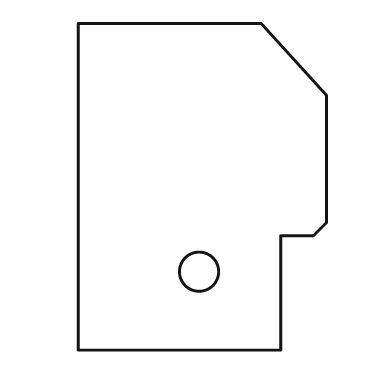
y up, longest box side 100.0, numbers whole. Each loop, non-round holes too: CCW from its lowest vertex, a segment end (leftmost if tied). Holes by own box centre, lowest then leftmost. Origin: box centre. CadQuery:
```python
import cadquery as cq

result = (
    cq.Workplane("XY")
    .moveTo(-38.0, -50.0)
    .lineTo(24.0, -50.0)
    .lineTo(24.0, -15.0)
    .lineTo(34.0, -15.0)
    .lineTo(38.0, -11.0)
    .lineTo(38.0, 28.0)
    .lineTo(18.0, 50.0)
    .lineTo(-38.0, 50.0)
    .close()
    .moveTo(-1.0, -26.0)
    .circle(6.0)
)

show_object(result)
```